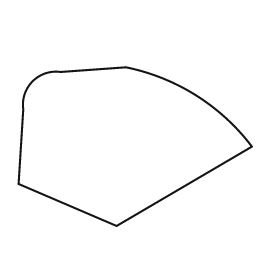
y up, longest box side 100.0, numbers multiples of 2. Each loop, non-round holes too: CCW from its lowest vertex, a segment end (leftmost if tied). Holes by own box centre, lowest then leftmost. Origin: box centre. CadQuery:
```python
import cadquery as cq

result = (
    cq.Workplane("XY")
    .moveTo(-8.0, -34.0)
    .lineTo(50.0, 0.0)
    .threePointArc((26.0, 22.0), (-4.0, 34.0))
    .lineTo(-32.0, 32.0)
    .threePointArc((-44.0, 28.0), (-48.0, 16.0))
    .lineTo(-50.0, -16.0)
    .close()
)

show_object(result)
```